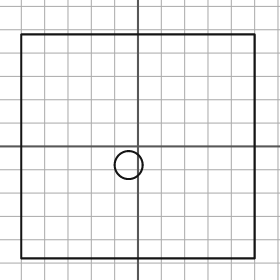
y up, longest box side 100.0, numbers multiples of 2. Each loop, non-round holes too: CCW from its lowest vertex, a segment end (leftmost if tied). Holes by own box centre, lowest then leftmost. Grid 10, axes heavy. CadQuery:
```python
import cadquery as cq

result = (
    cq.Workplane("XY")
    .moveTo(-50.0, -48.0)
    .lineTo(50.0, -48.0)
    .lineTo(50.0, 48.0)
    .lineTo(-50.0, 48.0)
    .close()
    .moveTo(-4.0, -8.0)
    .circle(6.0)
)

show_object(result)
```